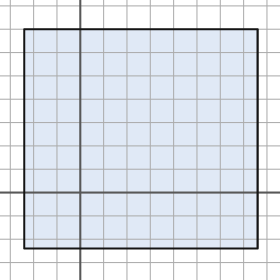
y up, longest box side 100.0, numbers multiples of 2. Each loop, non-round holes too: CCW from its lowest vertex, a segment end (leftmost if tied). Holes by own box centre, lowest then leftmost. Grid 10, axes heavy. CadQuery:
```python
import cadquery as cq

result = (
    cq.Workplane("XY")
    .moveTo(-24.0, -24.0)
    .lineTo(76.0, -24.0)
    .lineTo(76.0, 70.0)
    .lineTo(-24.0, 70.0)
    .close()
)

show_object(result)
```